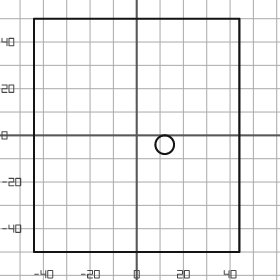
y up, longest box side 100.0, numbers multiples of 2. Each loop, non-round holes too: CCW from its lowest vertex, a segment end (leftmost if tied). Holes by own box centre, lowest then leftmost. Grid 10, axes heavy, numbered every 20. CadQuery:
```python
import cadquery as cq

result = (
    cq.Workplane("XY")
    .moveTo(-44.0, -50.0)
    .lineTo(44.0, -50.0)
    .lineTo(44.0, 50.0)
    .lineTo(-44.0, 50.0)
    .close()
    .moveTo(12.0, -4.0)
    .circle(4.0)
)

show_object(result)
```